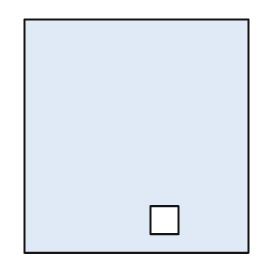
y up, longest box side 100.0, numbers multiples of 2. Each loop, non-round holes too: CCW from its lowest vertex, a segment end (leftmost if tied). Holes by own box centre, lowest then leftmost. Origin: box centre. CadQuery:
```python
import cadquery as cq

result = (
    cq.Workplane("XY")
    .moveTo(-48.0, -50.0)
    .lineTo(48.0, -50.0)
    .lineTo(48.0, 50.0)
    .lineTo(-48.0, 50.0)
    .close()
    .moveTo(6.0, -42.0)
    .lineTo(18.0, -42.0)
    .lineTo(18.0, -30.0)
    .lineTo(6.0, -30.0)
    .close()
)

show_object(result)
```